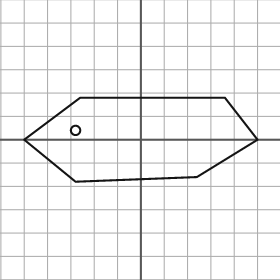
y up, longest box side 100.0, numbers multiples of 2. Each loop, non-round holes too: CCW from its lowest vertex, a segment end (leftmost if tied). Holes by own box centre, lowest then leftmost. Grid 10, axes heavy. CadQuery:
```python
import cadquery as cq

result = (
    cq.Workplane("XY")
    .moveTo(-28.0, -18.0)
    .lineTo(24.0, -16.0)
    .lineTo(50.0, 0.0)
    .lineTo(36.0, 18.0)
    .lineTo(-26.0, 18.0)
    .lineTo(-50.0, 0.0)
    .close()
    .moveTo(-28.0, 4.0)
    .circle(2.0)
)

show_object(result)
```